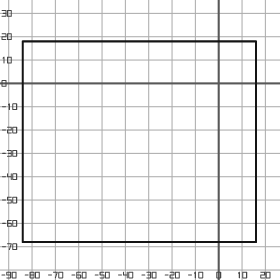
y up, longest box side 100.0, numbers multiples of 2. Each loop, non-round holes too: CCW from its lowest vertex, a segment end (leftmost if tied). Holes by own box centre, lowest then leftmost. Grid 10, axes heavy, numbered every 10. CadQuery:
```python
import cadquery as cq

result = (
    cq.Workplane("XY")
    .moveTo(-84.0, -68.0)
    .lineTo(16.0, -68.0)
    .lineTo(16.0, 18.0)
    .lineTo(-84.0, 18.0)
    .close()
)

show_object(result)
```